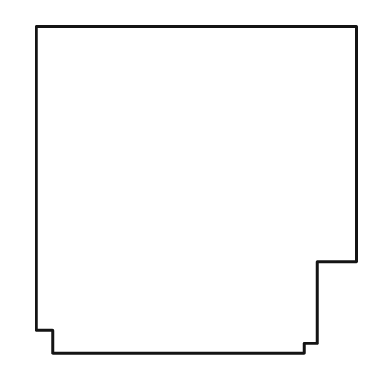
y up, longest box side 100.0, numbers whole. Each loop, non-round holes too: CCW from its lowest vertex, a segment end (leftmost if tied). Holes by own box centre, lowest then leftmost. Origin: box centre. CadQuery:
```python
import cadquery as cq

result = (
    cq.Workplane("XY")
    .moveTo(-44.0, -50.0)
    .lineTo(33.0, -50.0)
    .lineTo(33.0, -47.0)
    .lineTo(37.0, -47.0)
    .lineTo(37.0, -22.0)
    .lineTo(49.0, -22.0)
    .lineTo(49.0, 50.0)
    .lineTo(-49.0, 50.0)
    .lineTo(-49.0, -43.0)
    .lineTo(-44.0, -43.0)
    .close()
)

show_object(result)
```